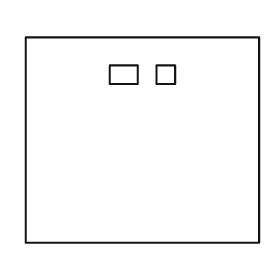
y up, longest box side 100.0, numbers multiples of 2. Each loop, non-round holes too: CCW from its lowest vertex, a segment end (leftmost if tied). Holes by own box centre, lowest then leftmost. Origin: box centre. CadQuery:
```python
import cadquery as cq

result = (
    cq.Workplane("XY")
    .moveTo(-50.0, -44.0)
    .lineTo(50.0, -44.0)
    .lineTo(50.0, 44.0)
    .lineTo(-50.0, 44.0)
    .close()
    .moveTo(-14.0, 24.0)
    .lineTo(-2.0, 24.0)
    .lineTo(-2.0, 32.0)
    .lineTo(-14.0, 32.0)
    .close()
    .moveTo(6.0, 24.0)
    .lineTo(14.0, 24.0)
    .lineTo(14.0, 32.0)
    .lineTo(6.0, 32.0)
    .close()
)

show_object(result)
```